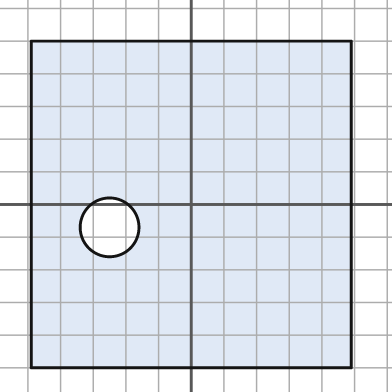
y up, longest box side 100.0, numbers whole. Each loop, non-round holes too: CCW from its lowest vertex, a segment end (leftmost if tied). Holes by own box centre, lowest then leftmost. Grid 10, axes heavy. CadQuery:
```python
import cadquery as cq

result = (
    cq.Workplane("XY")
    .moveTo(-49.0, -50.0)
    .lineTo(49.0, -50.0)
    .lineTo(49.0, 50.0)
    .lineTo(-49.0, 50.0)
    .close()
    .moveTo(-25.0, -7.0)
    .circle(9.0)
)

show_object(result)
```